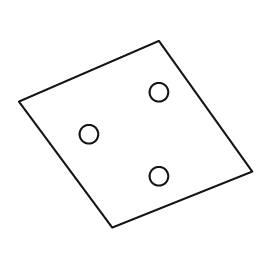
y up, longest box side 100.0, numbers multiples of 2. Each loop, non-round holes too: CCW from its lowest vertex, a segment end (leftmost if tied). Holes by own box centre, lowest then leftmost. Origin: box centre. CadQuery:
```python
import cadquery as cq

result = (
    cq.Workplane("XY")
    .moveTo(-10.0, -40.0)
    .lineTo(50.0, -16.0)
    .lineTo(10.0, 40.0)
    .lineTo(-50.0, 14.0)
    .close()
    .moveTo(10.0, -18.0)
    .circle(4.0)
    .moveTo(-20.0, 0.0)
    .circle(4.0)
    .moveTo(10.0, 18.0)
    .circle(4.0)
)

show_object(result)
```